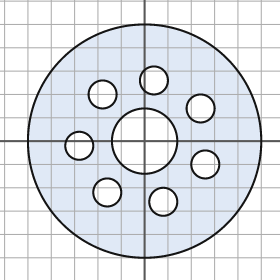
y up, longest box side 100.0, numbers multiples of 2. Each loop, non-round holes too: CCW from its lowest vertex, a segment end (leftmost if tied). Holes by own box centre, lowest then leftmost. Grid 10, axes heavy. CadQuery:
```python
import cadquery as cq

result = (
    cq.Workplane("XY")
    .moveTo(0.0, 0.0)
    .circle(50.0)
    .moveTo(8.0, -26.0)
    .circle(6.0)
    .moveTo(-16.0, -22.0)
    .circle(6.0)
    .moveTo(26.0, -10.0)
    .circle(6.0)
    .moveTo(-28.0, -2.0)
    .circle(6.0)
    .moveTo(0.0, 0.0)
    .circle(14.0)
    .moveTo(24.0, 14.0)
    .circle(6.0)
    .moveTo(-18.0, 20.0)
    .circle(6.0)
    .moveTo(4.0, 26.0)
    .circle(6.0)
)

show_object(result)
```